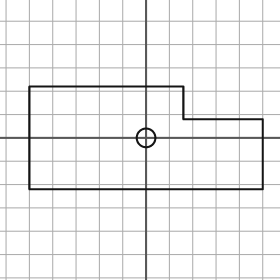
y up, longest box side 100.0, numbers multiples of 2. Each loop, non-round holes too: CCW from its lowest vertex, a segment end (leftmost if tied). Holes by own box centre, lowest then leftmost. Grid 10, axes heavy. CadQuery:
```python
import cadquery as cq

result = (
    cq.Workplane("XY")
    .moveTo(-50.0, -22.0)
    .lineTo(50.0, -22.0)
    .lineTo(50.0, 8.0)
    .lineTo(16.0, 8.0)
    .lineTo(16.0, 22.0)
    .lineTo(-50.0, 22.0)
    .close()
    .moveTo(0.0, 0.0)
    .circle(4.0)
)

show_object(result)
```